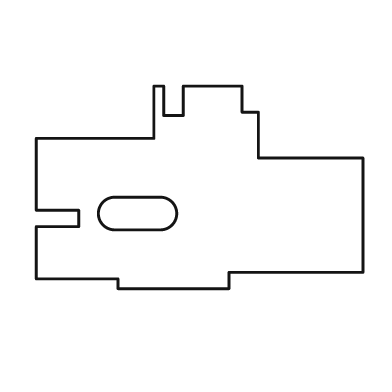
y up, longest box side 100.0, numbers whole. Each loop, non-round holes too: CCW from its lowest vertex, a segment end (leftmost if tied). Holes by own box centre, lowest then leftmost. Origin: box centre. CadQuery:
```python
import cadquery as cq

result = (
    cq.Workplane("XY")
    .moveTo(-25.0, -31.0)
    .lineTo(9.0, -31.0)
    .lineTo(9.0, -26.0)
    .lineTo(50.0, -26.0)
    .lineTo(50.0, 9.0)
    .lineTo(18.0, 9.0)
    .lineTo(18.0, 23.0)
    .lineTo(13.0, 23.0)
    .lineTo(13.0, 31.0)
    .lineTo(-5.0, 31.0)
    .lineTo(-5.0, 22.0)
    .lineTo(-11.0, 22.0)
    .lineTo(-11.0, 31.0)
    .lineTo(-14.0, 31.0)
    .lineTo(-14.0, 15.0)
    .lineTo(-50.0, 15.0)
    .lineTo(-50.0, -7.0)
    .lineTo(-37.0, -7.0)
    .lineTo(-37.0, -12.0)
    .lineTo(-50.0, -12.0)
    .lineTo(-50.0, -28.0)
    .lineTo(-25.0, -28.0)
    .close()
    .moveTo(-26.0, -13.0)
    .lineTo(-12.0, -13.0)
    .threePointArc((-7.0, -8.0), (-12.0, -3.0))
    .lineTo(-26.0, -3.0)
    .threePointArc((-31.0, -8.0), (-26.0, -13.0))
    .close()
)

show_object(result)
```